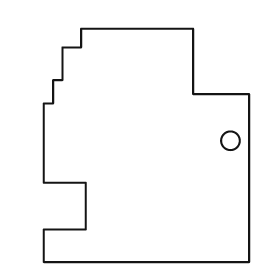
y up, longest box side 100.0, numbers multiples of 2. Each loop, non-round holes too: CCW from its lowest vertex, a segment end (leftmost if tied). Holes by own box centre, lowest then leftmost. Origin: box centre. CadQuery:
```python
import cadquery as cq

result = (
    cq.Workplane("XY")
    .moveTo(-44.0, -50.0)
    .lineTo(44.0, -50.0)
    .lineTo(44.0, 22.0)
    .lineTo(20.0, 22.0)
    .lineTo(20.0, 50.0)
    .lineTo(-28.0, 50.0)
    .lineTo(-28.0, 42.0)
    .lineTo(-36.0, 42.0)
    .lineTo(-36.0, 28.0)
    .lineTo(-40.0, 28.0)
    .lineTo(-40.0, 18.0)
    .lineTo(-44.0, 18.0)
    .lineTo(-44.0, -16.0)
    .lineTo(-26.0, -16.0)
    .lineTo(-26.0, -36.0)
    .lineTo(-44.0, -36.0)
    .close()
    .moveTo(36.0, 2.0)
    .circle(4.0)
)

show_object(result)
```